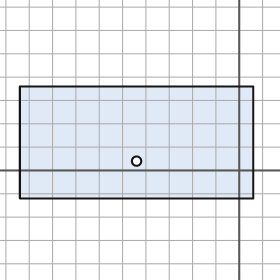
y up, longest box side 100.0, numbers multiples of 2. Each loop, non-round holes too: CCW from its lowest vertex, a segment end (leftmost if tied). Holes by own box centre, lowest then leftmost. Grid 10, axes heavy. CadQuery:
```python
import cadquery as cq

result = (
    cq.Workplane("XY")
    .moveTo(-94.0, -12.0)
    .lineTo(6.0, -12.0)
    .lineTo(6.0, 36.0)
    .lineTo(-94.0, 36.0)
    .close()
    .moveTo(-44.0, 4.0)
    .circle(2.0)
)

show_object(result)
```